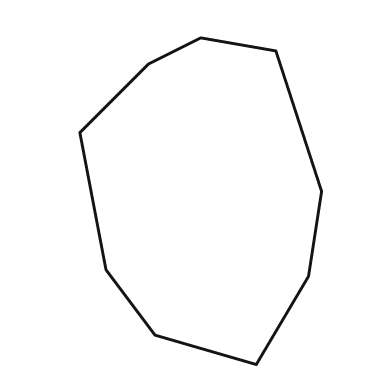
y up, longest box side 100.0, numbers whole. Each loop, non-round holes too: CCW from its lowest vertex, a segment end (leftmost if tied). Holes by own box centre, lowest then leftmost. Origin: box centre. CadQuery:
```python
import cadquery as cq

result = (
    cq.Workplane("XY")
    .moveTo(17.0, -50.0)
    .lineTo(33.0, -23.0)
    .lineTo(37.0, 3.0)
    .lineTo(23.0, 46.0)
    .lineTo(0.0, 50.0)
    .lineTo(-16.0, 42.0)
    .lineTo(-37.0, 21.0)
    .lineTo(-29.0, -21.0)
    .lineTo(-14.0, -41.0)
    .close()
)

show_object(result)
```